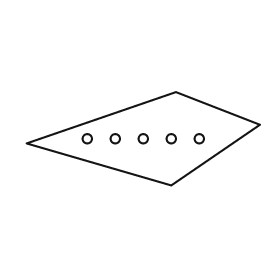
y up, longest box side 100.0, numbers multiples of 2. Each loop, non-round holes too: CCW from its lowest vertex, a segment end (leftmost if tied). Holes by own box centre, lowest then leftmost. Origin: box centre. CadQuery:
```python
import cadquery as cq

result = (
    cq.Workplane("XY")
    .moveTo(12.0, -20.0)
    .lineTo(50.0, 6.0)
    .lineTo(14.0, 20.0)
    .lineTo(-50.0, -2.0)
    .close()
    .moveTo(-24.0, 0.0)
    .circle(2.0)
    .moveTo(-12.0, 0.0)
    .circle(2.0)
    .moveTo(0.0, 0.0)
    .circle(2.0)
    .moveTo(12.0, 0.0)
    .circle(2.0)
    .moveTo(24.0, 0.0)
    .circle(2.0)
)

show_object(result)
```